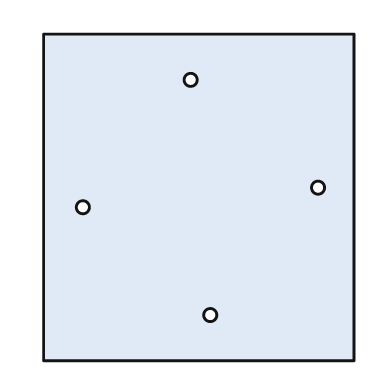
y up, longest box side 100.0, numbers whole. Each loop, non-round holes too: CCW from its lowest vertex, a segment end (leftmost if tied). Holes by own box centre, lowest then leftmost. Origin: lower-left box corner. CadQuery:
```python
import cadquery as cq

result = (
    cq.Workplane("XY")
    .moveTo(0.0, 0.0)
    .lineTo(95.0, 0.0)
    .lineTo(95.0, 100.0)
    .lineTo(0.0, 100.0)
    .close()
    .moveTo(51.0, 14.0)
    .circle(2.0)
    .moveTo(12.0, 47.0)
    .circle(2.0)
    .moveTo(84.0, 53.0)
    .circle(2.0)
    .moveTo(45.0, 86.0)
    .circle(2.0)
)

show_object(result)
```